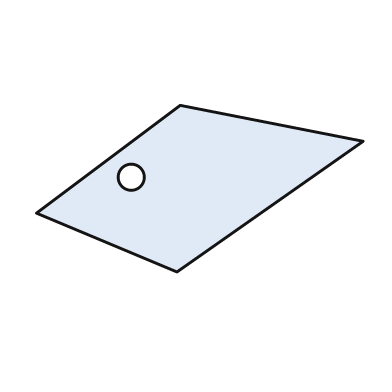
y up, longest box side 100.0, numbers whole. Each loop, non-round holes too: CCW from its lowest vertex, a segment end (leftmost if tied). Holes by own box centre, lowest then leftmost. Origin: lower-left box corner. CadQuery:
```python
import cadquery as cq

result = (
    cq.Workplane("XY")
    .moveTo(43.0, 0.0)
    .lineTo(100.0, 40.0)
    .lineTo(44.0, 51.0)
    .lineTo(0.0, 18.0)
    .close()
    .moveTo(29.0, 29.0)
    .circle(4.0)
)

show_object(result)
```